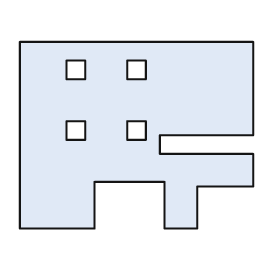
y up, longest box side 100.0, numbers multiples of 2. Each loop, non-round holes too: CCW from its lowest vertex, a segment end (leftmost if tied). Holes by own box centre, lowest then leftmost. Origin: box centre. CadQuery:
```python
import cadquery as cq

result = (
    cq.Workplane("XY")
    .moveTo(-50.0, -40.0)
    .lineTo(-18.0, -40.0)
    .lineTo(-18.0, -20.0)
    .lineTo(12.0, -20.0)
    .lineTo(12.0, -40.0)
    .lineTo(26.0, -40.0)
    .lineTo(26.0, -22.0)
    .lineTo(50.0, -22.0)
    .lineTo(50.0, -8.0)
    .lineTo(10.0, -8.0)
    .lineTo(10.0, 0.0)
    .lineTo(50.0, 0.0)
    .lineTo(50.0, 40.0)
    .lineTo(-50.0, 40.0)
    .close()
    .moveTo(-30.0, -2.0)
    .lineTo(-22.0, -2.0)
    .lineTo(-22.0, 6.0)
    .lineTo(-30.0, 6.0)
    .close()
    .moveTo(-4.0, -2.0)
    .lineTo(4.0, -2.0)
    .lineTo(4.0, 6.0)
    .lineTo(-4.0, 6.0)
    .close()
    .moveTo(-30.0, 24.0)
    .lineTo(-22.0, 24.0)
    .lineTo(-22.0, 32.0)
    .lineTo(-30.0, 32.0)
    .close()
    .moveTo(-4.0, 24.0)
    .lineTo(4.0, 24.0)
    .lineTo(4.0, 32.0)
    .lineTo(-4.0, 32.0)
    .close()
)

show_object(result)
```